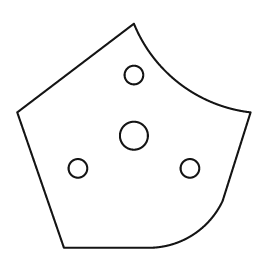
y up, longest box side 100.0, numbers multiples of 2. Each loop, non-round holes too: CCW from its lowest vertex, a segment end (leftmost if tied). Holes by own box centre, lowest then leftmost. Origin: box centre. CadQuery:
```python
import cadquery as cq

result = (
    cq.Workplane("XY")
    .moveTo(-30.0, -48.0)
    .lineTo(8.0, -48.0)
    .threePointArc((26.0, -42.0), (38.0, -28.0))
    .lineTo(50.0, 10.0)
    .threePointArc((20.0, 22.0), (0.0, 48.0))
    .lineTo(-50.0, 10.0)
    .close()
    .moveTo(-24.0, -14.0)
    .circle(4.0)
    .moveTo(24.0, -14.0)
    .circle(4.0)
    .moveTo(0.0, 0.0)
    .circle(6.0)
    .moveTo(0.0, 26.0)
    .circle(4.0)
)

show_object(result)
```